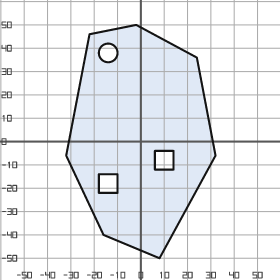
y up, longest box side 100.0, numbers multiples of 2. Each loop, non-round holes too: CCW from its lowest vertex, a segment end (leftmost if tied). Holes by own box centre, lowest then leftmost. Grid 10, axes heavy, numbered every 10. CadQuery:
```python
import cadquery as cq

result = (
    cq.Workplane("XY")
    .moveTo(8.0, -50.0)
    .lineTo(32.0, -6.0)
    .lineTo(24.0, 36.0)
    .lineTo(-2.0, 50.0)
    .lineTo(-22.0, 46.0)
    .lineTo(-32.0, -6.0)
    .lineTo(-16.0, -40.0)
    .close()
    .moveTo(-18.0, -22.0)
    .lineTo(-10.0, -22.0)
    .lineTo(-10.0, -14.0)
    .lineTo(-18.0, -14.0)
    .close()
    .moveTo(6.0, -12.0)
    .lineTo(14.0, -12.0)
    .lineTo(14.0, -4.0)
    .lineTo(6.0, -4.0)
    .close()
    .moveTo(-14.0, 38.0)
    .circle(4.0)
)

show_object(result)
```